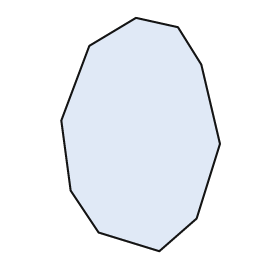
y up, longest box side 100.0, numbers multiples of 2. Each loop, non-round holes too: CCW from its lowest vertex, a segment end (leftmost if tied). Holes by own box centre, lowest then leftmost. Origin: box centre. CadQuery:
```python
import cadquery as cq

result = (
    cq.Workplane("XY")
    .moveTo(8.0, -50.0)
    .lineTo(24.0, -36.0)
    .lineTo(34.0, -4.0)
    .lineTo(26.0, 30.0)
    .lineTo(16.0, 46.0)
    .lineTo(-2.0, 50.0)
    .lineTo(-22.0, 38.0)
    .lineTo(-34.0, 6.0)
    .lineTo(-30.0, -24.0)
    .lineTo(-18.0, -42.0)
    .close()
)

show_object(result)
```